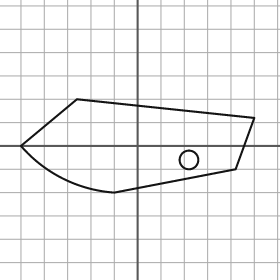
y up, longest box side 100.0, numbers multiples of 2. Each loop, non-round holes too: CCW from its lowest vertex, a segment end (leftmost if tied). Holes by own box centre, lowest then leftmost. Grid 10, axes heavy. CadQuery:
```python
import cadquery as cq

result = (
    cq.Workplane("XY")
    .moveTo(-10.0, -20.0)
    .lineTo(42.0, -10.0)
    .lineTo(50.0, 12.0)
    .lineTo(-26.0, 20.0)
    .lineTo(-50.0, 0.0)
    .threePointArc((-32.0, -14.0), (-10.0, -20.0))
    .close()
    .moveTo(22.0, -6.0)
    .circle(4.0)
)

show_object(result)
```